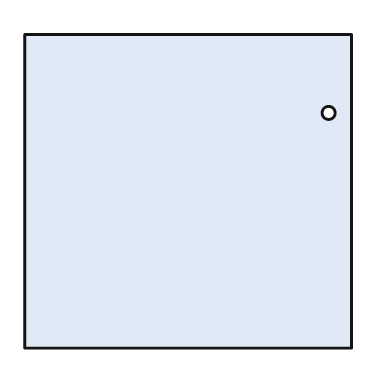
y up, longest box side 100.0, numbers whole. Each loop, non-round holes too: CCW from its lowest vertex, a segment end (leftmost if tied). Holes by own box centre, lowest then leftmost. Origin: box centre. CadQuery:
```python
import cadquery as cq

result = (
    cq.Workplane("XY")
    .moveTo(-50.0, -48.0)
    .lineTo(50.0, -48.0)
    .lineTo(50.0, 48.0)
    .lineTo(-50.0, 48.0)
    .close()
    .moveTo(43.0, 24.0)
    .circle(2.0)
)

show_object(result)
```